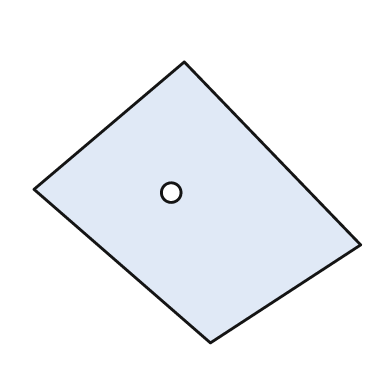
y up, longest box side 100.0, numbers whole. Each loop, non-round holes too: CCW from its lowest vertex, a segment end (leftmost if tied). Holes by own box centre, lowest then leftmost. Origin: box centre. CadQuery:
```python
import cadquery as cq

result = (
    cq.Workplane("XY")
    .moveTo(4.0, -43.0)
    .lineTo(50.0, -13.0)
    .lineTo(-4.0, 43.0)
    .lineTo(-50.0, 4.0)
    .close()
    .moveTo(-8.0, 3.0)
    .circle(3.0)
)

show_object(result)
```